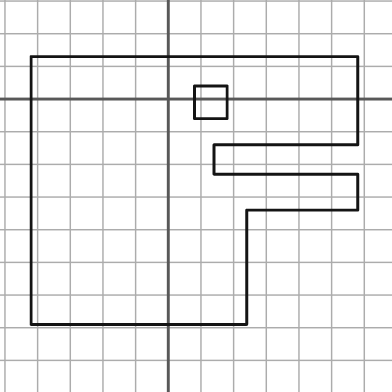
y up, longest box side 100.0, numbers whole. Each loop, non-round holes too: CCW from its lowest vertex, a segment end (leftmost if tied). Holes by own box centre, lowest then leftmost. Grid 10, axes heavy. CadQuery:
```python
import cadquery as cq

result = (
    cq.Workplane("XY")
    .moveTo(-42.0, -69.0)
    .lineTo(24.0, -69.0)
    .lineTo(24.0, -34.0)
    .lineTo(58.0, -34.0)
    .lineTo(58.0, -23.0)
    .lineTo(14.0, -23.0)
    .lineTo(14.0, -14.0)
    .lineTo(58.0, -14.0)
    .lineTo(58.0, 13.0)
    .lineTo(-42.0, 13.0)
    .close()
    .moveTo(8.0, -6.0)
    .lineTo(18.0, -6.0)
    .lineTo(18.0, 4.0)
    .lineTo(8.0, 4.0)
    .close()
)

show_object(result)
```